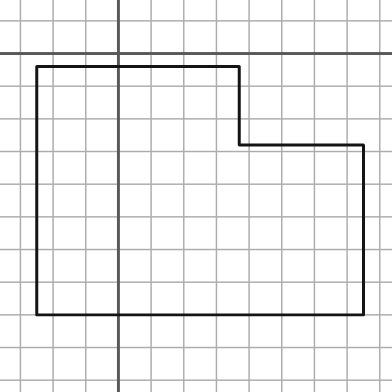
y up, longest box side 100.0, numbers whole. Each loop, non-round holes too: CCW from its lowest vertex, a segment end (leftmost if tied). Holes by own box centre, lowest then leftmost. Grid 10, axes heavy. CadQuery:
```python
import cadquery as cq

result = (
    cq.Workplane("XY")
    .moveTo(-25.0, -80.0)
    .lineTo(75.0, -80.0)
    .lineTo(75.0, -28.0)
    .lineTo(37.0, -28.0)
    .lineTo(37.0, -4.0)
    .lineTo(-25.0, -4.0)
    .close()
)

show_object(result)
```